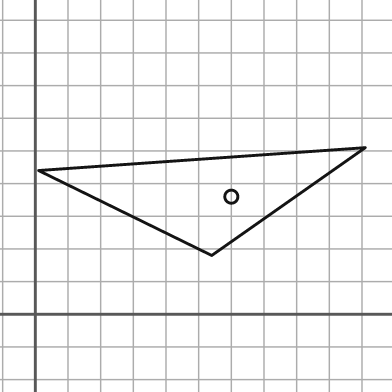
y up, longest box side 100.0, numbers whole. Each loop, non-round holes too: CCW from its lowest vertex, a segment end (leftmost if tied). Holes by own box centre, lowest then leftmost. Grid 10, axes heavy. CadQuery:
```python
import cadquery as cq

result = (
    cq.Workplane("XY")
    .moveTo(54.0, 18.0)
    .lineTo(101.0, 51.0)
    .lineTo(1.0, 44.0)
    .close()
    .moveTo(60.0, 36.0)
    .circle(2.0)
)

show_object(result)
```